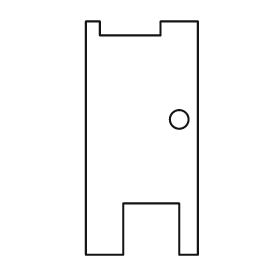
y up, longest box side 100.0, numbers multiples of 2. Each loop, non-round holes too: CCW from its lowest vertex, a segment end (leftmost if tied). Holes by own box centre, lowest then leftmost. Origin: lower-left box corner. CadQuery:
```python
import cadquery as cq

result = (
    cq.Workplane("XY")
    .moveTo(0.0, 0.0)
    .lineTo(16.0, 0.0)
    .lineTo(16.0, 22.0)
    .lineTo(40.0, 22.0)
    .lineTo(40.0, 0.0)
    .lineTo(48.0, 0.0)
    .lineTo(48.0, 100.0)
    .lineTo(32.0, 100.0)
    .lineTo(32.0, 94.0)
    .lineTo(6.0, 94.0)
    .lineTo(6.0, 100.0)
    .lineTo(0.0, 100.0)
    .close()
    .moveTo(40.0, 58.0)
    .circle(4.0)
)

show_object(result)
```